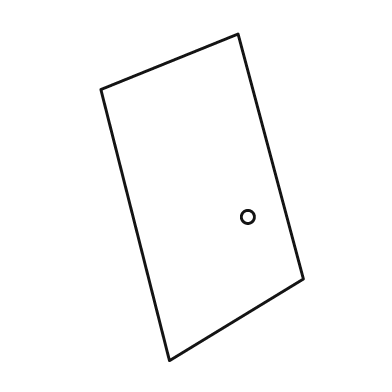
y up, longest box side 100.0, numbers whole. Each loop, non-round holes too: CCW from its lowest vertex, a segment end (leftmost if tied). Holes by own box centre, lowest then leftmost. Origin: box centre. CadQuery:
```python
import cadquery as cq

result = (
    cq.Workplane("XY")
    .moveTo(-10.0, -50.0)
    .lineTo(31.0, -25.0)
    .lineTo(11.0, 50.0)
    .lineTo(-31.0, 33.0)
    .close()
    .moveTo(14.0, -6.0)
    .circle(2.0)
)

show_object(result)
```